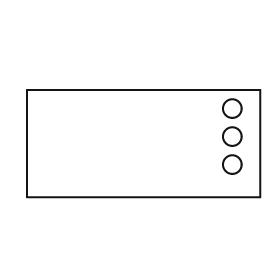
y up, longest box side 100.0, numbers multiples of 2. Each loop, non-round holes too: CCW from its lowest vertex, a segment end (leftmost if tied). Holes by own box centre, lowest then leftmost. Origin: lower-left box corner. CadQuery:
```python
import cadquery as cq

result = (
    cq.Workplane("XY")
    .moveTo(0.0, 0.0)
    .lineTo(100.0, 0.0)
    .lineTo(100.0, 46.0)
    .lineTo(0.0, 46.0)
    .close()
    .moveTo(88.0, 14.0)
    .circle(4.0)
    .moveTo(88.0, 26.0)
    .circle(4.0)
    .moveTo(88.0, 38.0)
    .circle(4.0)
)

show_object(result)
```